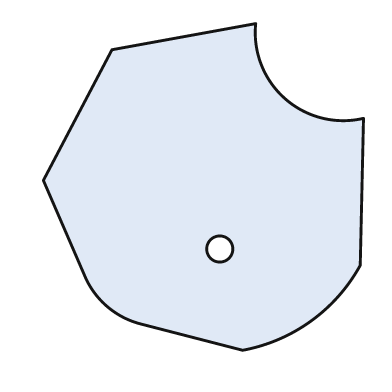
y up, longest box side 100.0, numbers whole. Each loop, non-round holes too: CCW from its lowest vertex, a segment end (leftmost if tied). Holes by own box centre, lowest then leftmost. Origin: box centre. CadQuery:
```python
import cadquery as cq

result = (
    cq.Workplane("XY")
    .moveTo(12.0, -50.0)
    .threePointArc((33.0, -41.0), (48.0, -24.0))
    .lineTo(49.0, 21.0)
    .threePointArc((25.0, 27.0), (16.0, 50.0))
    .lineTo(-28.0, 42.0)
    .lineTo(-49.0, 2.0)
    .lineTo(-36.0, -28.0)
    .threePointArc((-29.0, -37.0), (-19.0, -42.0))
    .close()
    .moveTo(5.0, -19.0)
    .circle(4.0)
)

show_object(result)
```